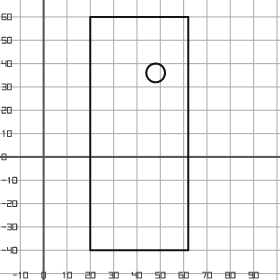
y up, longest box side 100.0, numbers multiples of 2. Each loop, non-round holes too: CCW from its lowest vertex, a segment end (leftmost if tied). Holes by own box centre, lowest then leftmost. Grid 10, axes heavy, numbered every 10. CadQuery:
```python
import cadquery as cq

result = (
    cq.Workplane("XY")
    .moveTo(20.0, -40.0)
    .lineTo(62.0, -40.0)
    .lineTo(62.0, 60.0)
    .lineTo(20.0, 60.0)
    .close()
    .moveTo(48.0, 36.0)
    .circle(4.0)
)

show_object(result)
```